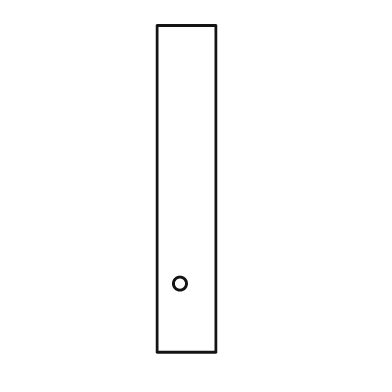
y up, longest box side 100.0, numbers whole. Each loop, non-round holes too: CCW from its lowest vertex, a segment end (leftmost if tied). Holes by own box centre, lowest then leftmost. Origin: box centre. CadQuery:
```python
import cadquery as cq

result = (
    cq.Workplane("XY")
    .moveTo(-9.0, -50.0)
    .lineTo(9.0, -50.0)
    .lineTo(9.0, 50.0)
    .lineTo(-9.0, 50.0)
    .close()
    .moveTo(-2.0, -29.0)
    .circle(2.0)
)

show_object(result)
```